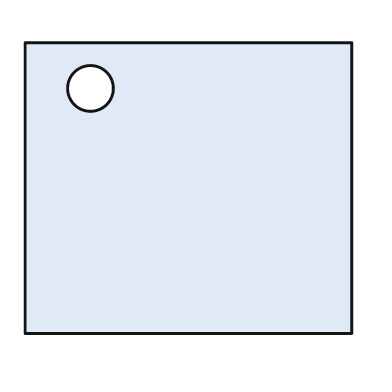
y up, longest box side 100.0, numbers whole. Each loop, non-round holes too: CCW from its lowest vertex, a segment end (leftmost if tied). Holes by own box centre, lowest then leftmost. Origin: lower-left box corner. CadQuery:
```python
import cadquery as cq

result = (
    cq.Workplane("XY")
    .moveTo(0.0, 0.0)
    .lineTo(100.0, 0.0)
    .lineTo(100.0, 89.0)
    .lineTo(0.0, 89.0)
    .close()
    .moveTo(20.0, 75.0)
    .circle(7.0)
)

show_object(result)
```